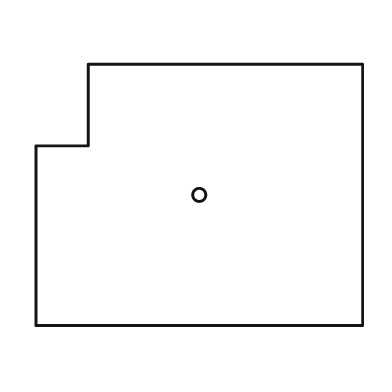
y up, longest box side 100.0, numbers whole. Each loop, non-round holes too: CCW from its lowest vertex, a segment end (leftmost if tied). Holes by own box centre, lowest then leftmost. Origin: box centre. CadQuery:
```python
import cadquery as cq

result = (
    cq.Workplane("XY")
    .moveTo(-50.0, -40.0)
    .lineTo(50.0, -40.0)
    .lineTo(50.0, 40.0)
    .lineTo(-34.0, 40.0)
    .lineTo(-34.0, 15.0)
    .lineTo(-50.0, 15.0)
    .close()
    .moveTo(0.0, 0.0)
    .circle(2.0)
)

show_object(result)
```